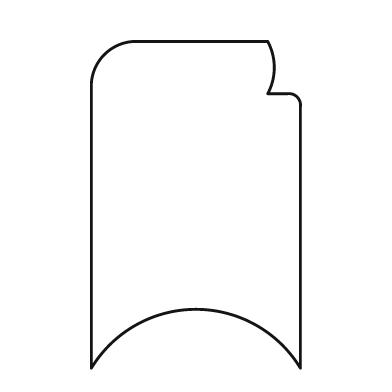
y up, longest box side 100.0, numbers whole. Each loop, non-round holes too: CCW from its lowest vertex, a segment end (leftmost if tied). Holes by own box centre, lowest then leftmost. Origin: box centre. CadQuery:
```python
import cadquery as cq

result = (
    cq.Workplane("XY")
    .moveTo(-32.0, -50.0)
    .threePointArc((0.0, -32.0), (32.0, -50.0))
    .lineTo(32.0, 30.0)
    .threePointArc((31.0, 33.0), (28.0, 34.0))
    .lineTo(22.0, 34.0)
    .threePointArc((24.0, 42.0), (22.0, 50.0))
    .lineTo(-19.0, 50.0)
    .threePointArc((-28.0, 46.0), (-32.0, 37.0))
    .close()
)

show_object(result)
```